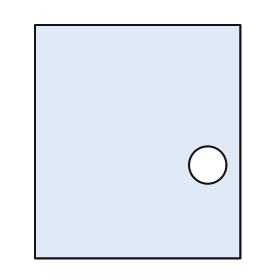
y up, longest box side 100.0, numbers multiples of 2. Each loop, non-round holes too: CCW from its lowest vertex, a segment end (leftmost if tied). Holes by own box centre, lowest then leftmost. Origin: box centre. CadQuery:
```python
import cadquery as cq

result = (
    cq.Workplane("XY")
    .moveTo(-44.0, -50.0)
    .lineTo(44.0, -50.0)
    .lineTo(44.0, 50.0)
    .lineTo(-44.0, 50.0)
    .close()
    .moveTo(30.0, -10.0)
    .circle(8.0)
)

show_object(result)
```